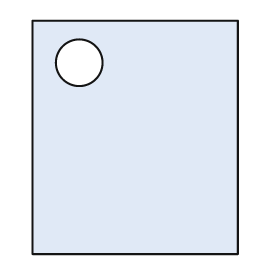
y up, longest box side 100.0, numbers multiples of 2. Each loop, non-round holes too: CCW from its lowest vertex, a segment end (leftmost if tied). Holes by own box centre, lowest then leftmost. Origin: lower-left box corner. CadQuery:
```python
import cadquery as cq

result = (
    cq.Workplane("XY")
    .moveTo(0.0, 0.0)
    .lineTo(88.0, 0.0)
    .lineTo(88.0, 100.0)
    .lineTo(0.0, 100.0)
    .close()
    .moveTo(20.0, 82.0)
    .circle(10.0)
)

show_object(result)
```